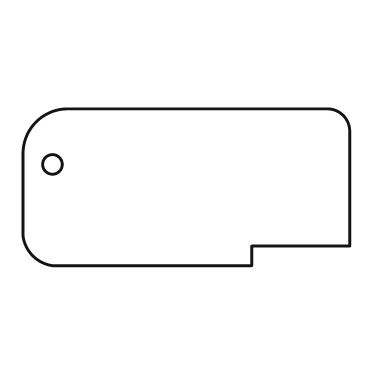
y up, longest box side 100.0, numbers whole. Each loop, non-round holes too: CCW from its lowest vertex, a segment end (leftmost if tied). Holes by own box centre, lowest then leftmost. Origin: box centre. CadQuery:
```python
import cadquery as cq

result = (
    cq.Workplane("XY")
    .moveTo(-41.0, -24.0)
    .lineTo(20.0, -24.0)
    .lineTo(20.0, -18.0)
    .lineTo(50.0, -18.0)
    .lineTo(50.0, 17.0)
    .threePointArc((48.0, 22.0), (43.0, 24.0))
    .lineTo(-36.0, 24.0)
    .threePointArc((-46.0, 20.0), (-50.0, 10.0))
    .lineTo(-50.0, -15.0)
    .threePointArc((-47.0, -21.0), (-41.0, -24.0))
    .close()
    .moveTo(-41.0, 7.0)
    .circle(3.0)
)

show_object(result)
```